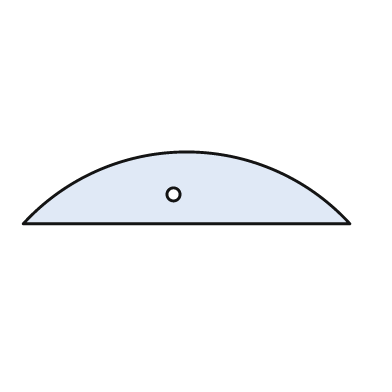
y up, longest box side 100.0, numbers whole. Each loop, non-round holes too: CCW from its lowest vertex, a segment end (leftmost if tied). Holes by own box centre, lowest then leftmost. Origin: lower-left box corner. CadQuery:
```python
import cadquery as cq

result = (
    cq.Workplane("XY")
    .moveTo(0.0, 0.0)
    .lineTo(100.0, 0.0)
    .threePointArc((50.0, 22.0), (0.0, 0.0))
    .close()
    .moveTo(46.0, 9.0)
    .circle(2.0)
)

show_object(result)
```